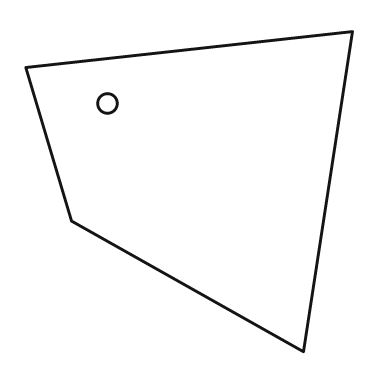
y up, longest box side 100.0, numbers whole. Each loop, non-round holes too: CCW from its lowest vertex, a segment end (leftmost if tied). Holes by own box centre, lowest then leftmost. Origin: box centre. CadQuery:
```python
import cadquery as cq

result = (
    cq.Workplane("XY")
    .moveTo(35.0, -49.0)
    .lineTo(50.0, 49.0)
    .lineTo(-50.0, 38.0)
    .lineTo(-36.0, -9.0)
    .close()
    .moveTo(-25.0, 27.0)
    .circle(3.0)
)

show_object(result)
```